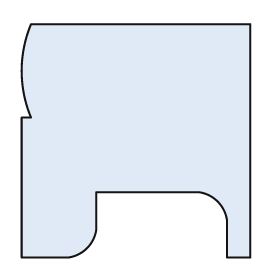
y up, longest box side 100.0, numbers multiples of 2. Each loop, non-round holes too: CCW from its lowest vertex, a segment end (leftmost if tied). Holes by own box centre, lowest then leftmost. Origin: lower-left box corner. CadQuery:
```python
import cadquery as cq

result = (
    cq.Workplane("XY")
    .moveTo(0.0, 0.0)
    .lineTo(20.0, 0.0)
    .threePointArc((28.0, 4.0), (32.0, 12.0))
    .lineTo(32.0, 28.0)
    .lineTo(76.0, 28.0)
    .threePointArc((84.0, 24.0), (88.0, 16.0))
    .lineTo(88.0, 0.0)
    .lineTo(98.0, 0.0)
    .lineTo(98.0, 100.0)
    .lineTo(4.0, 100.0)
    .threePointArc((0.0, 80.0), (4.0, 60.0))
    .lineTo(0.0, 60.0)
    .close()
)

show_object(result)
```